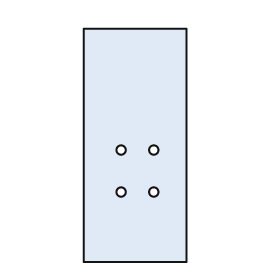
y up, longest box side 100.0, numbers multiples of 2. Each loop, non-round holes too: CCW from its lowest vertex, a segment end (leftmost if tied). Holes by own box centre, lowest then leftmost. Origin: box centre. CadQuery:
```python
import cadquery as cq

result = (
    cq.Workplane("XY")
    .moveTo(-22.0, -50.0)
    .lineTo(22.0, -50.0)
    .lineTo(22.0, 50.0)
    .lineTo(-22.0, 50.0)
    .close()
    .moveTo(-6.0, -20.0)
    .circle(2.0)
    .moveTo(8.0, -20.0)
    .circle(2.0)
    .moveTo(-6.0, -2.0)
    .circle(2.0)
    .moveTo(8.0, -2.0)
    .circle(2.0)
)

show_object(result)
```